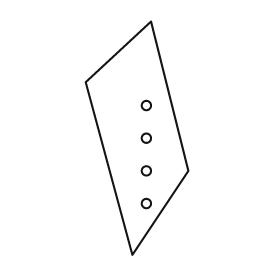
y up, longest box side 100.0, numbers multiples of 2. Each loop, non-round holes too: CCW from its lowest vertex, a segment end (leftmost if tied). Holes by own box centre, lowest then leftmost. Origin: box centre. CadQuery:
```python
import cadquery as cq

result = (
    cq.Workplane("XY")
    .moveTo(-2.0, -50.0)
    .lineTo(22.0, -14.0)
    .lineTo(6.0, 50.0)
    .lineTo(-22.0, 24.0)
    .close()
    .moveTo(4.0, -28.0)
    .circle(2.0)
    .moveTo(4.0, -14.0)
    .circle(2.0)
    .moveTo(4.0, 0.0)
    .circle(2.0)
    .moveTo(4.0, 14.0)
    .circle(2.0)
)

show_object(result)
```